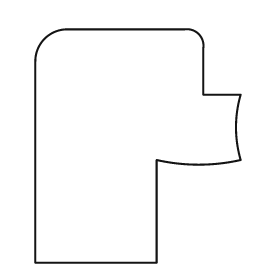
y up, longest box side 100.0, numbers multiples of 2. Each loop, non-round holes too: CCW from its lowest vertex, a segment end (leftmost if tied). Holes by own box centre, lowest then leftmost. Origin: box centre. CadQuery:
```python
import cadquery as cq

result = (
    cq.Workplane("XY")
    .moveTo(-44.0, -50.0)
    .lineTo(8.0, -50.0)
    .lineTo(8.0, -6.0)
    .threePointArc((26.0, -8.0), (44.0, -6.0))
    .threePointArc((42.0, 8.0), (44.0, 22.0))
    .lineTo(28.0, 22.0)
    .lineTo(28.0, 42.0)
    .threePointArc((26.0, 48.0), (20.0, 50.0))
    .lineTo(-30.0, 50.0)
    .threePointArc((-40.0, 46.0), (-44.0, 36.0))
    .close()
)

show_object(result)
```